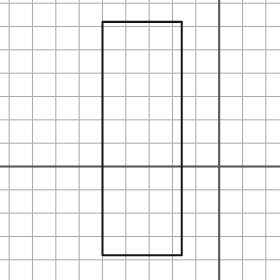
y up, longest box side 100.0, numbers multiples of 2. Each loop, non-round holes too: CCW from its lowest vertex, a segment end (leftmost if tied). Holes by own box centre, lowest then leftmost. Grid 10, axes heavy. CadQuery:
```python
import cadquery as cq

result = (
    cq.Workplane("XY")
    .moveTo(-50.0, -38.0)
    .lineTo(-16.0, -38.0)
    .lineTo(-16.0, 62.0)
    .lineTo(-50.0, 62.0)
    .close()
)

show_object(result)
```